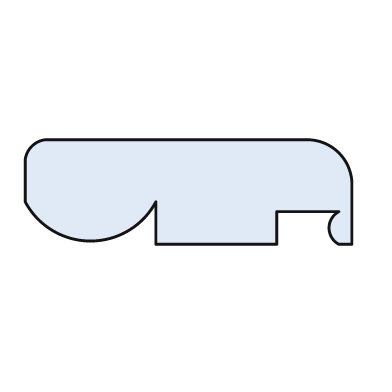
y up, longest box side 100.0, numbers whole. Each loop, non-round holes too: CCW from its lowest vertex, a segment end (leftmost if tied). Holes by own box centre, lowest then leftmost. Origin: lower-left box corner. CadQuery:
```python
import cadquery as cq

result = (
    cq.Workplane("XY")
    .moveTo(40.0, 0.0)
    .lineTo(77.0, 0.0)
    .lineTo(77.0, 10.0)
    .lineTo(96.0, 10.0)
    .threePointArc((93.0, 5.0), (96.0, 0.0))
    .lineTo(100.0, 0.0)
    .lineTo(100.0, 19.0)
    .threePointArc((96.0, 28.0), (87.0, 32.0))
    .lineTo(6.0, 32.0)
    .threePointArc((2.0, 30.0), (0.0, 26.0))
    .lineTo(0.0, 13.0)
    .threePointArc((20.0, 1.0), (40.0, 13.0))
    .close()
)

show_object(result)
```